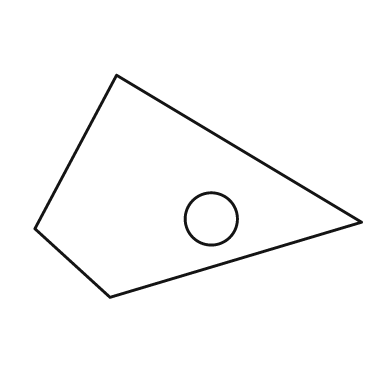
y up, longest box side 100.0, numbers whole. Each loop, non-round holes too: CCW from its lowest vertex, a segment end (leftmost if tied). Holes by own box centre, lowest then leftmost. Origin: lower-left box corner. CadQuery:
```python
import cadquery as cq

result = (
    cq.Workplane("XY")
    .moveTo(23.0, 0.0)
    .lineTo(100.0, 23.0)
    .lineTo(25.0, 68.0)
    .lineTo(0.0, 21.0)
    .close()
    .moveTo(54.0, 24.0)
    .circle(8.0)
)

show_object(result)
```